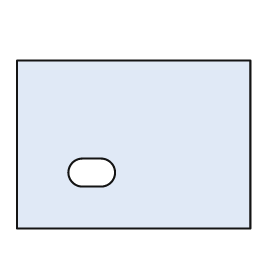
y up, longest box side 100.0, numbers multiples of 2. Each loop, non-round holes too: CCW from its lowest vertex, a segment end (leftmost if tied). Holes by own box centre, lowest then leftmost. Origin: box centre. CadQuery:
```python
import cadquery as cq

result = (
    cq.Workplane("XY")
    .moveTo(-50.0, -36.0)
    .lineTo(50.0, -36.0)
    .lineTo(50.0, 36.0)
    .lineTo(-50.0, 36.0)
    .close()
    .moveTo(-22.0, -18.0)
    .lineTo(-14.0, -18.0)
    .threePointArc((-8.0, -12.0), (-14.0, -6.0))
    .lineTo(-22.0, -6.0)
    .threePointArc((-28.0, -12.0), (-22.0, -18.0))
    .close()
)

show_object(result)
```